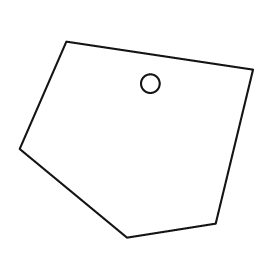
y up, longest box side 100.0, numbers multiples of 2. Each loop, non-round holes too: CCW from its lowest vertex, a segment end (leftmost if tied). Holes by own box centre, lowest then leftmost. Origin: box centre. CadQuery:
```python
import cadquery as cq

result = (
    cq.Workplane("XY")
    .moveTo(-4.0, -42.0)
    .lineTo(34.0, -36.0)
    .lineTo(50.0, 30.0)
    .lineTo(-30.0, 42.0)
    .lineTo(-50.0, -4.0)
    .close()
    .moveTo(6.0, 24.0)
    .circle(4.0)
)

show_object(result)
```